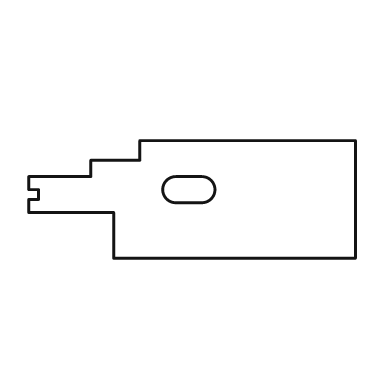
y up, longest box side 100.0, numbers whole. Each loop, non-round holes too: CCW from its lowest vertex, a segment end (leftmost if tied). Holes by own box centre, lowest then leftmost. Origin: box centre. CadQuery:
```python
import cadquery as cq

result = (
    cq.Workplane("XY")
    .moveTo(-24.0, -18.0)
    .lineTo(50.0, -18.0)
    .lineTo(50.0, 18.0)
    .lineTo(-16.0, 18.0)
    .lineTo(-16.0, 12.0)
    .lineTo(-31.0, 12.0)
    .lineTo(-31.0, 7.0)
    .lineTo(-50.0, 7.0)
    .lineTo(-50.0, 3.0)
    .lineTo(-47.0, 3.0)
    .lineTo(-47.0, 0.0)
    .lineTo(-50.0, 0.0)
    .lineTo(-50.0, -4.0)
    .lineTo(-24.0, -4.0)
    .close()
    .moveTo(-5.0, -1.0)
    .lineTo(3.0, -1.0)
    .threePointArc((7.0, 3.0), (3.0, 7.0))
    .lineTo(-5.0, 7.0)
    .threePointArc((-9.0, 3.0), (-5.0, -1.0))
    .close()
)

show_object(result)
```